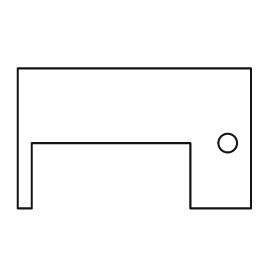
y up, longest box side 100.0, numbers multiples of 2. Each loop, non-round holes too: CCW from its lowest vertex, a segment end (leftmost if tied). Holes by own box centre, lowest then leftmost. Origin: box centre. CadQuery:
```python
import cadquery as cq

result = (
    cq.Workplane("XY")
    .moveTo(-50.0, -30.0)
    .lineTo(-44.0, -30.0)
    .lineTo(-44.0, -2.0)
    .lineTo(24.0, -2.0)
    .lineTo(24.0, -30.0)
    .lineTo(50.0, -30.0)
    .lineTo(50.0, 30.0)
    .lineTo(-50.0, 30.0)
    .close()
    .moveTo(40.0, -2.0)
    .circle(4.0)
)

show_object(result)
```